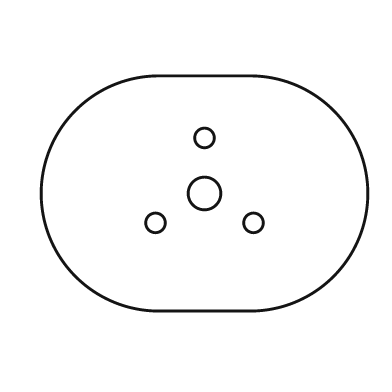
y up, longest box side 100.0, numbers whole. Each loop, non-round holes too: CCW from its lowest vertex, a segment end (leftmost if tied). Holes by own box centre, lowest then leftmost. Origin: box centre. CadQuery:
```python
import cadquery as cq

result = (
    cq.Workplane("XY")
    .moveTo(-14.0, -36.0)
    .lineTo(14.0, -36.0)
    .threePointArc((50.0, 0.0), (14.0, 36.0))
    .lineTo(-14.0, 36.0)
    .threePointArc((-50.0, 0.0), (-14.0, -36.0))
    .close()
    .moveTo(-15.0, -9.0)
    .circle(3.0)
    .moveTo(15.0, -9.0)
    .circle(3.0)
    .moveTo(0.0, 0.0)
    .circle(5.0)
    .moveTo(0.0, 17.0)
    .circle(3.0)
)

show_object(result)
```